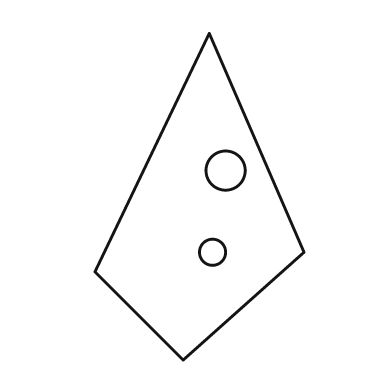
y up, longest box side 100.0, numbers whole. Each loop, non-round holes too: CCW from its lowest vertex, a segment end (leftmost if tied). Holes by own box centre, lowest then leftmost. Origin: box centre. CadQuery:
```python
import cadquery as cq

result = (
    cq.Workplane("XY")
    .moveTo(-5.0, -50.0)
    .lineTo(32.0, -17.0)
    .lineTo(3.0, 50.0)
    .lineTo(-32.0, -23.0)
    .close()
    .moveTo(4.0, -17.0)
    .circle(4.0)
    .moveTo(8.0, 8.0)
    .circle(6.0)
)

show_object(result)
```